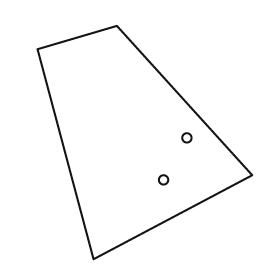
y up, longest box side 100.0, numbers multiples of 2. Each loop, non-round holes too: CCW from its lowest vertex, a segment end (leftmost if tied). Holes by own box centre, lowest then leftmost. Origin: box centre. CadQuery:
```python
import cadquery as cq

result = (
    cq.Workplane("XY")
    .moveTo(-22.0, -50.0)
    .lineTo(46.0, -14.0)
    .lineTo(-12.0, 50.0)
    .lineTo(-46.0, 40.0)
    .close()
    .moveTo(8.0, -16.0)
    .circle(2.0)
    .moveTo(18.0, 2.0)
    .circle(2.0)
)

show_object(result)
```